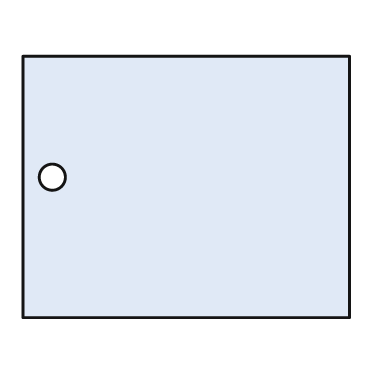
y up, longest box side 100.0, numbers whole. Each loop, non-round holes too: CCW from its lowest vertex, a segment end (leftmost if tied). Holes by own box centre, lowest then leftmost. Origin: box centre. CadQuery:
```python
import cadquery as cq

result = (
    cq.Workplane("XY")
    .moveTo(-50.0, -40.0)
    .lineTo(50.0, -40.0)
    .lineTo(50.0, 40.0)
    .lineTo(-50.0, 40.0)
    .close()
    .moveTo(-41.0, 3.0)
    .circle(4.0)
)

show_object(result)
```